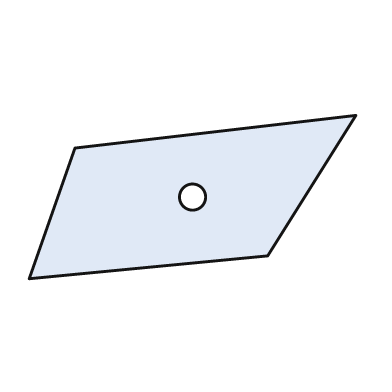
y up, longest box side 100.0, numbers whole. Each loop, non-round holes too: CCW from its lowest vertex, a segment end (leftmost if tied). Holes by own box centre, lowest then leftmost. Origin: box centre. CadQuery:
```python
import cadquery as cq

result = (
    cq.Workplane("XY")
    .moveTo(-50.0, -25.0)
    .lineTo(23.0, -18.0)
    .lineTo(50.0, 25.0)
    .lineTo(-36.0, 15.0)
    .close()
    .moveTo(0.0, 0.0)
    .circle(4.0)
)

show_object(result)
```